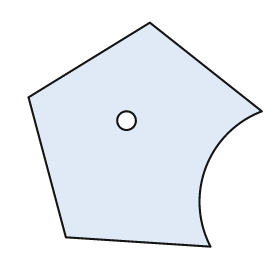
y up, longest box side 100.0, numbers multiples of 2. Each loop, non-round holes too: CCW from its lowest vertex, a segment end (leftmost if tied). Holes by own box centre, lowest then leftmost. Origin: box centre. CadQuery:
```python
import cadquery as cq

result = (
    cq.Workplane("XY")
    .moveTo(28.0, -48.0)
    .threePointArc((26.0, -14.0), (50.0, 10.0))
    .lineTo(2.0, 48.0)
    .lineTo(-50.0, 16.0)
    .lineTo(-34.0, -44.0)
    .close()
    .moveTo(-8.0, 6.0)
    .circle(4.0)
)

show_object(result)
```